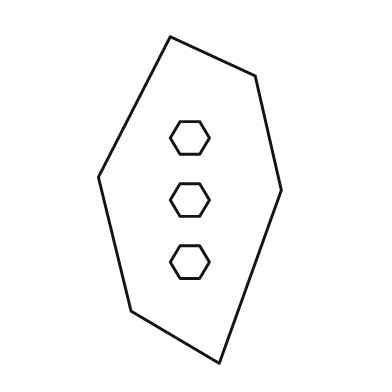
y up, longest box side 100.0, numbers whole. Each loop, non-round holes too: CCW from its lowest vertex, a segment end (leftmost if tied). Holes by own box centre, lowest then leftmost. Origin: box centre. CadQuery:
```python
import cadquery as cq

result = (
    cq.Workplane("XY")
    .moveTo(9.0, -50.0)
    .lineTo(28.0, 3.0)
    .lineTo(20.0, 38.0)
    .lineTo(-6.0, 50.0)
    .lineTo(-28.0, 7.0)
    .lineTo(-18.0, -34.0)
    .close()
    .moveTo(-3.0, -24.0)
    .lineTo(3.0, -24.0)
    .lineTo(6.0, -19.0)
    .lineTo(3.0, -14.0)
    .lineTo(-3.0, -14.0)
    .lineTo(-6.0, -19.0)
    .close()
    .moveTo(-3.0, -5.0)
    .lineTo(3.0, -5.0)
    .lineTo(6.0, 0.0)
    .lineTo(3.0, 5.0)
    .lineTo(-3.0, 5.0)
    .lineTo(-6.0, 0.0)
    .close()
    .moveTo(-3.0, 14.0)
    .lineTo(3.0, 14.0)
    .lineTo(6.0, 19.0)
    .lineTo(3.0, 24.0)
    .lineTo(-3.0, 24.0)
    .lineTo(-6.0, 19.0)
    .close()
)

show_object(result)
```